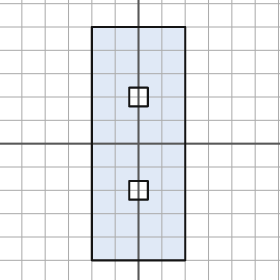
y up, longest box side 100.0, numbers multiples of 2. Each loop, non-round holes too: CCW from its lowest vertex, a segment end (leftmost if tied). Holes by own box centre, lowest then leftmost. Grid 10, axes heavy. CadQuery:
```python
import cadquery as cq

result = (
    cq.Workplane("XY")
    .moveTo(-20.0, -50.0)
    .lineTo(20.0, -50.0)
    .lineTo(20.0, 50.0)
    .lineTo(-20.0, 50.0)
    .close()
    .moveTo(-4.0, -24.0)
    .lineTo(4.0, -24.0)
    .lineTo(4.0, -16.0)
    .lineTo(-4.0, -16.0)
    .close()
    .moveTo(-4.0, 16.0)
    .lineTo(4.0, 16.0)
    .lineTo(4.0, 24.0)
    .lineTo(-4.0, 24.0)
    .close()
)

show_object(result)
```